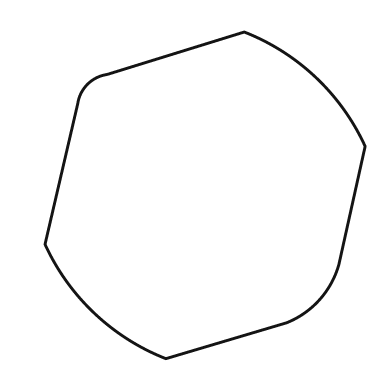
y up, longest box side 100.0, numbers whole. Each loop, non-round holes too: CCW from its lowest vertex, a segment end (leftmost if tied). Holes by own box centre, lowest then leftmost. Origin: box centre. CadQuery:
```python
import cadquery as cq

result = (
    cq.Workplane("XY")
    .moveTo(-12.0, -50.0)
    .lineTo(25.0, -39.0)
    .threePointArc((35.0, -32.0), (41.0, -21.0))
    .lineTo(49.0, 15.0)
    .threePointArc((34.0, 36.0), (12.0, 50.0))
    .lineTo(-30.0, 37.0)
    .threePointArc((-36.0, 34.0), (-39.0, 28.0))
    .lineTo(-49.0, -15.0)
    .threePointArc((-34.0, -36.0), (-12.0, -50.0))
    .close()
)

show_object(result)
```